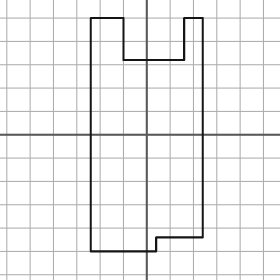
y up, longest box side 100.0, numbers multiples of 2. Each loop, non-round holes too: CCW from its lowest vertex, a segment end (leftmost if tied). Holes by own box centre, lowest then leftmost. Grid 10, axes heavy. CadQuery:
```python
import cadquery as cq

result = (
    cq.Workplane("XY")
    .moveTo(-24.0, -50.0)
    .lineTo(4.0, -50.0)
    .lineTo(4.0, -44.0)
    .lineTo(24.0, -44.0)
    .lineTo(24.0, 50.0)
    .lineTo(16.0, 50.0)
    .lineTo(16.0, 32.0)
    .lineTo(-10.0, 32.0)
    .lineTo(-10.0, 50.0)
    .lineTo(-24.0, 50.0)
    .close()
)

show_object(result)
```